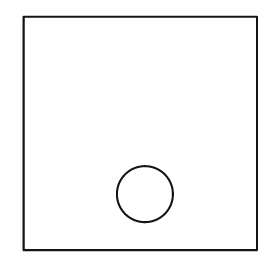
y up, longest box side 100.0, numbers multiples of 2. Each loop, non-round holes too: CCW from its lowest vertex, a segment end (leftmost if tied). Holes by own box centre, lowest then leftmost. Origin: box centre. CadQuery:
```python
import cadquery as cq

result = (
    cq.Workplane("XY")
    .moveTo(-50.0, -50.0)
    .lineTo(50.0, -50.0)
    .lineTo(50.0, 50.0)
    .lineTo(-50.0, 50.0)
    .close()
    .moveTo(2.0, -26.0)
    .circle(12.0)
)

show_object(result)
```